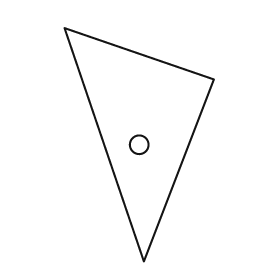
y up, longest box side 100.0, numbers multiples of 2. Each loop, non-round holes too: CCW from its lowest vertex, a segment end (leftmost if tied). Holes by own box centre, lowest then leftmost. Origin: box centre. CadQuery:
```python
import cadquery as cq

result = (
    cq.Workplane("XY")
    .moveTo(2.0, -50.0)
    .lineTo(32.0, 28.0)
    .lineTo(-32.0, 50.0)
    .close()
    .moveTo(0.0, 0.0)
    .circle(4.0)
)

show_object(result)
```